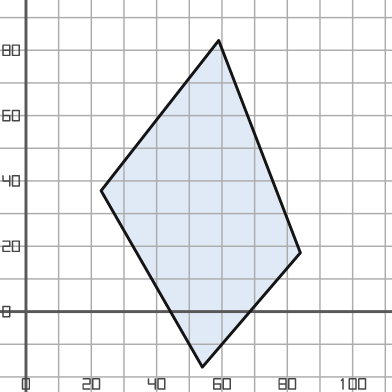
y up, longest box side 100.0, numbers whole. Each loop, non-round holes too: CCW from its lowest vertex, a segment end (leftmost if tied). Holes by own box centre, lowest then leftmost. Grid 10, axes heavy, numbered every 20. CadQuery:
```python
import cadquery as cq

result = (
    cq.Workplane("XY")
    .moveTo(54.0, -17.0)
    .lineTo(84.0, 18.0)
    .lineTo(59.0, 83.0)
    .lineTo(23.0, 37.0)
    .close()
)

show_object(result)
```